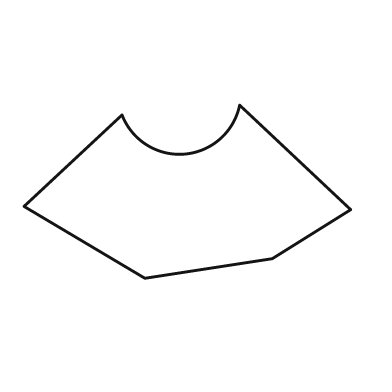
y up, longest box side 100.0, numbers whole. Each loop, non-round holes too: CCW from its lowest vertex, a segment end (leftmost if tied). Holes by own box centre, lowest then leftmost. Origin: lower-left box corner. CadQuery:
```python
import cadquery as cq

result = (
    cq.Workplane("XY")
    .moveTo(37.0, 0.0)
    .lineTo(76.0, 6.0)
    .lineTo(100.0, 21.0)
    .lineTo(66.0, 53.0)
    .threePointArc((49.0, 38.0), (30.0, 50.0))
    .lineTo(0.0, 22.0)
    .close()
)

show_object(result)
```